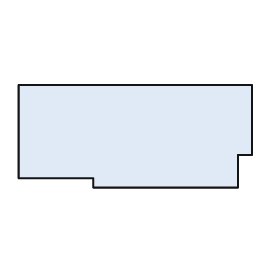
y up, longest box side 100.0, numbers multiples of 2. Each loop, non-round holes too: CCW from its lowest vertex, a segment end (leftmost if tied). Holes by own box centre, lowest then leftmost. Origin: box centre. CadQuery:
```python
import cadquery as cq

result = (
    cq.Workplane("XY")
    .moveTo(-18.0, -22.0)
    .lineTo(44.0, -22.0)
    .lineTo(44.0, -8.0)
    .lineTo(50.0, -8.0)
    .lineTo(50.0, 22.0)
    .lineTo(-50.0, 22.0)
    .lineTo(-50.0, -18.0)
    .lineTo(-18.0, -18.0)
    .close()
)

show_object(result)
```